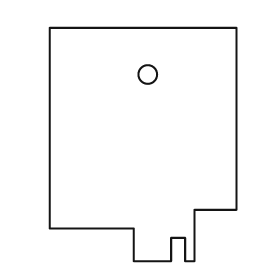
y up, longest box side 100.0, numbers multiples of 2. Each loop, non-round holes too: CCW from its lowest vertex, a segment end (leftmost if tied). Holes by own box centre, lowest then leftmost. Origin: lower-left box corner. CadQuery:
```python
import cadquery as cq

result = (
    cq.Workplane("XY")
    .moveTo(36.0, 0.0)
    .lineTo(52.0, 0.0)
    .lineTo(52.0, 10.0)
    .lineTo(58.0, 10.0)
    .lineTo(58.0, 0.0)
    .lineTo(62.0, 0.0)
    .lineTo(62.0, 22.0)
    .lineTo(80.0, 22.0)
    .lineTo(80.0, 100.0)
    .lineTo(0.0, 100.0)
    .lineTo(0.0, 14.0)
    .lineTo(36.0, 14.0)
    .close()
    .moveTo(42.0, 80.0)
    .circle(4.0)
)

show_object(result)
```